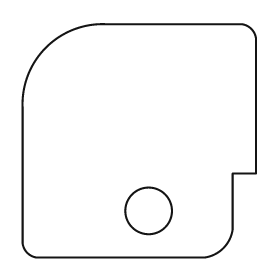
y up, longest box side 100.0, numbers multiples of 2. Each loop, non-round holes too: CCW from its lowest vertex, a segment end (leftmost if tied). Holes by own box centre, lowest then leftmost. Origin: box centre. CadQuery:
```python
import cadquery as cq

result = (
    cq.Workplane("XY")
    .moveTo(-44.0, -50.0)
    .lineTo(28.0, -50.0)
    .threePointArc((36.0, -46.0), (40.0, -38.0))
    .lineTo(40.0, -14.0)
    .lineTo(50.0, -14.0)
    .lineTo(50.0, 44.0)
    .threePointArc((48.0, 48.0), (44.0, 50.0))
    .lineTo(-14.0, 50.0)
    .threePointArc((-40.0, 40.0), (-50.0, 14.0))
    .lineTo(-50.0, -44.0)
    .threePointArc((-48.0, -48.0), (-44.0, -50.0))
    .close()
    .moveTo(4.0, -30.0)
    .circle(10.0)
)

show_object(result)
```